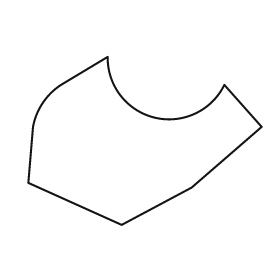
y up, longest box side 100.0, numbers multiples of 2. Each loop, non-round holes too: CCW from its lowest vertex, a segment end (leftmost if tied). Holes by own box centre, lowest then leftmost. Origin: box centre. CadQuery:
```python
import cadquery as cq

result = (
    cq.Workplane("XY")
    .moveTo(-10.0, -36.0)
    .lineTo(20.0, -20.0)
    .lineTo(50.0, 6.0)
    .lineTo(34.0, 24.0)
    .threePointArc((4.0, 10.0), (-16.0, 36.0))
    .lineTo(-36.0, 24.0)
    .threePointArc((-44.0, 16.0), (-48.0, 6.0))
    .lineTo(-50.0, -18.0)
    .close()
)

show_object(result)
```